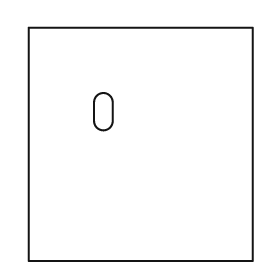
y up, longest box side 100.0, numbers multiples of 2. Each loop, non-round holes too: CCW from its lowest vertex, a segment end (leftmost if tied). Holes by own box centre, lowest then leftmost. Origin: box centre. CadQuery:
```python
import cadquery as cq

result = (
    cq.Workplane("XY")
    .moveTo(-48.0, -50.0)
    .lineTo(48.0, -50.0)
    .lineTo(48.0, 50.0)
    .lineTo(-48.0, 50.0)
    .close()
    .moveTo(-20.0, 10.0)
    .threePointArc((-16.0, 6.0), (-12.0, 10.0))
    .lineTo(-12.0, 18.0)
    .threePointArc((-16.0, 22.0), (-20.0, 18.0))
    .close()
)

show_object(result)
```